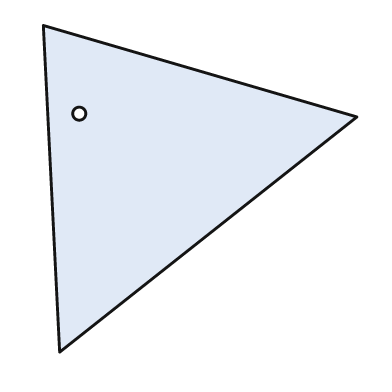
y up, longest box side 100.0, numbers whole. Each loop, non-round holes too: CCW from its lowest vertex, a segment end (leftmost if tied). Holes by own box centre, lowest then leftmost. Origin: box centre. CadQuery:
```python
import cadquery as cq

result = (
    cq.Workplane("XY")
    .moveTo(-43.0, -50.0)
    .lineTo(48.0, 22.0)
    .lineTo(-48.0, 50.0)
    .close()
    .moveTo(-37.0, 23.0)
    .circle(2.0)
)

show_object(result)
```